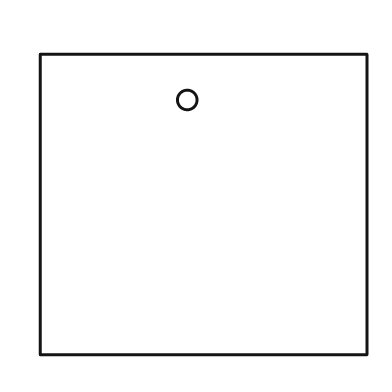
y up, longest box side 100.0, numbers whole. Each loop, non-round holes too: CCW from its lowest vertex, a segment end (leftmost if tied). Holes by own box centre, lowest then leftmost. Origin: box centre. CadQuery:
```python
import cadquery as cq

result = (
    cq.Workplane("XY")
    .moveTo(-50.0, -46.0)
    .lineTo(50.0, -46.0)
    .lineTo(50.0, 46.0)
    .lineTo(-50.0, 46.0)
    .close()
    .moveTo(-5.0, 32.0)
    .circle(3.0)
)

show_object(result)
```